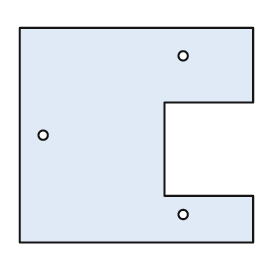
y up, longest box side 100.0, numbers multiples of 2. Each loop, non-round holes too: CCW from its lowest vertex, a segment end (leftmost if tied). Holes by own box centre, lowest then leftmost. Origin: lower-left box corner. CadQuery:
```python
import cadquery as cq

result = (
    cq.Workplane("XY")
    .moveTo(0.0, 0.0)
    .lineTo(100.0, 0.0)
    .lineTo(100.0, 20.0)
    .lineTo(62.0, 20.0)
    .lineTo(62.0, 60.0)
    .lineTo(100.0, 60.0)
    .lineTo(100.0, 92.0)
    .lineTo(0.0, 92.0)
    .close()
    .moveTo(70.0, 12.0)
    .circle(2.0)
    .moveTo(10.0, 46.0)
    .circle(2.0)
    .moveTo(70.0, 80.0)
    .circle(2.0)
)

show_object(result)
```